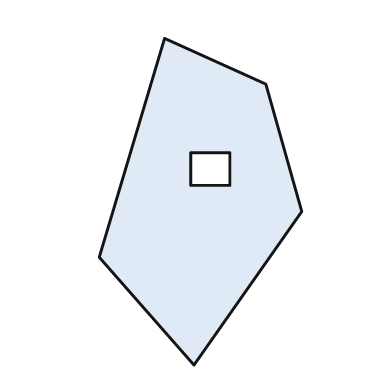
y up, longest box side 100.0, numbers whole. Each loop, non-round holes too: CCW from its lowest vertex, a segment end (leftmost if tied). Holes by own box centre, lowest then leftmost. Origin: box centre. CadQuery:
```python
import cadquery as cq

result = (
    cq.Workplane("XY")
    .moveTo(-2.0, -50.0)
    .lineTo(31.0, -3.0)
    .lineTo(20.0, 36.0)
    .lineTo(-11.0, 50.0)
    .lineTo(-31.0, -17.0)
    .close()
    .moveTo(-3.0, 5.0)
    .lineTo(9.0, 5.0)
    .lineTo(9.0, 15.0)
    .lineTo(-3.0, 15.0)
    .close()
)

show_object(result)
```